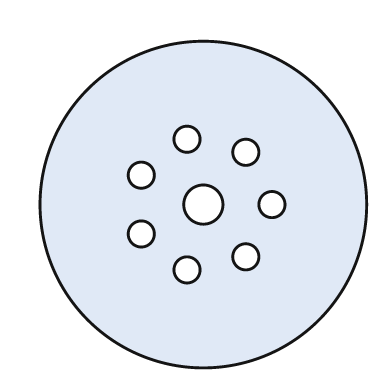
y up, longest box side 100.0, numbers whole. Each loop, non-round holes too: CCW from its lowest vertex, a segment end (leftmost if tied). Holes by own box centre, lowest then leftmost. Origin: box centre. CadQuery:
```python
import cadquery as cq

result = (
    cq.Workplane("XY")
    .moveTo(0.0, 0.0)
    .circle(50.0)
    .moveTo(-5.0, -20.0)
    .circle(4.0)
    .moveTo(13.0, -16.0)
    .circle(4.0)
    .moveTo(-19.0, -9.0)
    .circle(4.0)
    .moveTo(0.0, 0.0)
    .circle(6.0)
    .moveTo(21.0, 0.0)
    .circle(4.0)
    .moveTo(-19.0, 9.0)
    .circle(4.0)
    .moveTo(13.0, 16.0)
    .circle(4.0)
    .moveTo(-5.0, 20.0)
    .circle(4.0)
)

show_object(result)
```